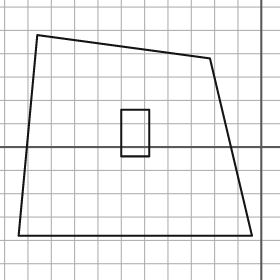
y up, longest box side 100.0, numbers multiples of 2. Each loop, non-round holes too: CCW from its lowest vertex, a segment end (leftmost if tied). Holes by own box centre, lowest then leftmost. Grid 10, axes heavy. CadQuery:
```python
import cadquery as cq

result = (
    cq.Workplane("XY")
    .moveTo(-104.0, -38.0)
    .lineTo(-4.0, -38.0)
    .lineTo(-22.0, 38.0)
    .lineTo(-96.0, 48.0)
    .close()
    .moveTo(-60.0, -4.0)
    .lineTo(-48.0, -4.0)
    .lineTo(-48.0, 16.0)
    .lineTo(-60.0, 16.0)
    .close()
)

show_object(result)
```